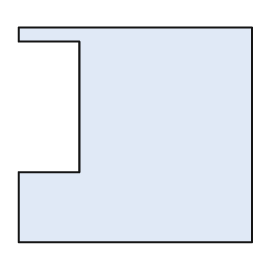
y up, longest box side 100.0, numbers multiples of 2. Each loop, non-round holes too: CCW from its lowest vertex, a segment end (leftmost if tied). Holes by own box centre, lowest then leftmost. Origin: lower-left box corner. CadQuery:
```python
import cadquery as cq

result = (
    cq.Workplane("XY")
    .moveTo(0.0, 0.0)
    .lineTo(100.0, 0.0)
    .lineTo(100.0, 92.0)
    .lineTo(0.0, 92.0)
    .lineTo(0.0, 86.0)
    .lineTo(26.0, 86.0)
    .lineTo(26.0, 30.0)
    .lineTo(0.0, 30.0)
    .close()
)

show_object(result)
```